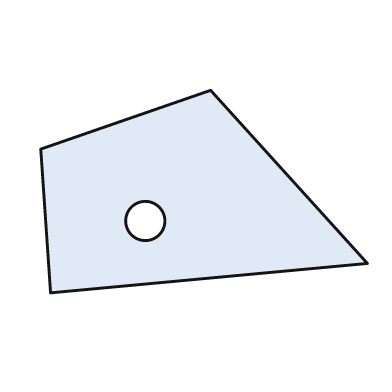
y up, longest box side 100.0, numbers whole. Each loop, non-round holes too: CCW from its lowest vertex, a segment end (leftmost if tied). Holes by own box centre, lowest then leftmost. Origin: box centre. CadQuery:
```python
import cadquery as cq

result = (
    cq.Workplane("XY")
    .moveTo(-47.0, -31.0)
    .lineTo(50.0, -22.0)
    .lineTo(2.0, 31.0)
    .lineTo(-50.0, 13.0)
    .close()
    .moveTo(-18.0, -9.0)
    .circle(6.0)
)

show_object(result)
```